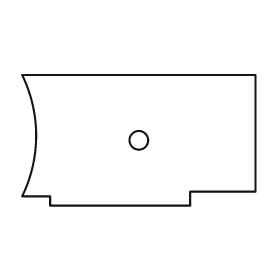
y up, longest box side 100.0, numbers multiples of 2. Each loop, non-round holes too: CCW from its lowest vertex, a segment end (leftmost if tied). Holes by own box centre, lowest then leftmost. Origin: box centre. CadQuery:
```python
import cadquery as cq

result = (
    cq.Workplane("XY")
    .moveTo(-38.0, -28.0)
    .lineTo(22.0, -28.0)
    .lineTo(22.0, -22.0)
    .lineTo(50.0, -22.0)
    .lineTo(50.0, 28.0)
    .lineTo(-50.0, 28.0)
    .threePointArc((-44.0, 2.0), (-50.0, -24.0))
    .lineTo(-38.0, -24.0)
    .close()
    .moveTo(0.0, 0.0)
    .circle(4.0)
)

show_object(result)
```